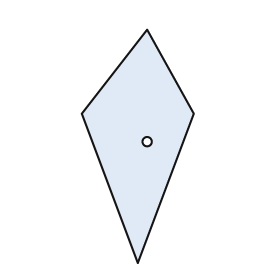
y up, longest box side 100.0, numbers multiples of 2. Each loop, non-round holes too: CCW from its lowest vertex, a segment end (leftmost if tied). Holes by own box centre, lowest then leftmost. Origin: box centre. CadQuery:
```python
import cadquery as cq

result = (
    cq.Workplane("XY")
    .moveTo(0.0, -50.0)
    .lineTo(24.0, 14.0)
    .lineTo(4.0, 50.0)
    .lineTo(-24.0, 14.0)
    .close()
    .moveTo(4.0, 2.0)
    .circle(2.0)
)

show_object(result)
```